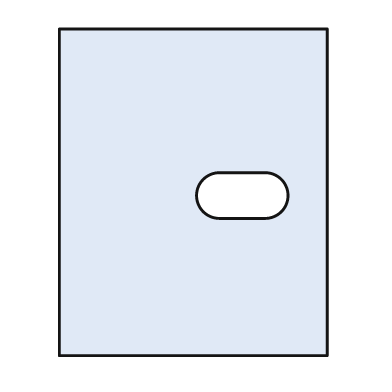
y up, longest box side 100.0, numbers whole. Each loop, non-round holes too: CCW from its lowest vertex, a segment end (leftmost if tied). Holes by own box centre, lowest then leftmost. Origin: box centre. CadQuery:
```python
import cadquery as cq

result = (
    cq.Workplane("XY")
    .moveTo(-41.0, -50.0)
    .lineTo(41.0, -50.0)
    .lineTo(41.0, 50.0)
    .lineTo(-41.0, 50.0)
    .close()
    .moveTo(8.0, -8.0)
    .lineTo(22.0, -8.0)
    .threePointArc((29.0, -1.0), (22.0, 6.0))
    .lineTo(8.0, 6.0)
    .threePointArc((1.0, -1.0), (8.0, -8.0))
    .close()
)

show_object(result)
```